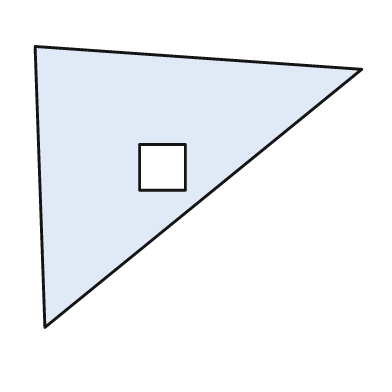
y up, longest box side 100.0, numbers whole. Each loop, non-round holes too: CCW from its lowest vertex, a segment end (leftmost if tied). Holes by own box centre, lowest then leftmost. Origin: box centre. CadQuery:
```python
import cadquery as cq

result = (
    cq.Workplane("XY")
    .moveTo(-47.0, -43.0)
    .lineTo(50.0, 36.0)
    .lineTo(-50.0, 43.0)
    .close()
    .moveTo(-18.0, -1.0)
    .lineTo(-4.0, -1.0)
    .lineTo(-4.0, 13.0)
    .lineTo(-18.0, 13.0)
    .close()
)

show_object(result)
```